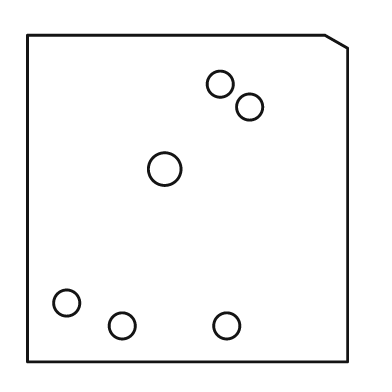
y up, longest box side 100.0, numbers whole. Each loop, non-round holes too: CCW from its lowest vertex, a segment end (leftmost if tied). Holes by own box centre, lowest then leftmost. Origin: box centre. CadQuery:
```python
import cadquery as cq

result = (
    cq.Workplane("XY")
    .moveTo(-49.0, -50.0)
    .lineTo(49.0, -50.0)
    .lineTo(49.0, 46.0)
    .lineTo(42.0, 50.0)
    .lineTo(-49.0, 50.0)
    .close()
    .moveTo(-20.0, -39.0)
    .circle(4.0)
    .moveTo(12.0, -39.0)
    .circle(4.0)
    .moveTo(-37.0, -32.0)
    .circle(4.0)
    .moveTo(-7.0, 9.0)
    .circle(5.0)
    .moveTo(19.0, 28.0)
    .circle(4.0)
    .moveTo(10.0, 35.0)
    .circle(4.0)
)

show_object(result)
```